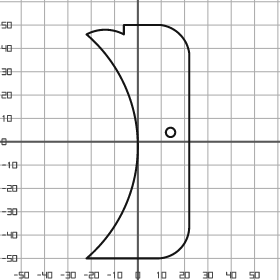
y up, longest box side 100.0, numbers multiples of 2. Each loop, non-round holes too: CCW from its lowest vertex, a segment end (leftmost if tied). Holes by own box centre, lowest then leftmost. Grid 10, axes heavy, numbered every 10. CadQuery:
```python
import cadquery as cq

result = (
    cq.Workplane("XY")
    .moveTo(-22.0, -50.0)
    .lineTo(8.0, -50.0)
    .threePointArc((18.0, -46.0), (22.0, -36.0))
    .lineTo(22.0, 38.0)
    .threePointArc((18.0, 46.0), (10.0, 50.0))
    .lineTo(-6.0, 50.0)
    .lineTo(-6.0, 46.0)
    .threePointArc((-14.0, 48.0), (-22.0, 46.0))
    .threePointArc((0.0, -2.0), (-22.0, -50.0))
    .close()
    .moveTo(14.0, 4.0)
    .circle(2.0)
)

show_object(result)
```